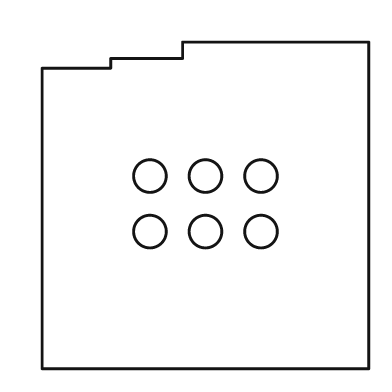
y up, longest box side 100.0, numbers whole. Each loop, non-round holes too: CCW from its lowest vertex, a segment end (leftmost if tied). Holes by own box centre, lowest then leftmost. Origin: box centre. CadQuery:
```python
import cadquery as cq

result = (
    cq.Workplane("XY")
    .moveTo(-50.0, -50.0)
    .lineTo(50.0, -50.0)
    .lineTo(50.0, 50.0)
    .lineTo(-7.0, 50.0)
    .lineTo(-7.0, 45.0)
    .lineTo(-29.0, 45.0)
    .lineTo(-29.0, 42.0)
    .lineTo(-50.0, 42.0)
    .close()
    .moveTo(-17.0, -8.0)
    .circle(5.0)
    .moveTo(0.0, -8.0)
    .circle(5.0)
    .moveTo(17.0, -8.0)
    .circle(5.0)
    .moveTo(-17.0, 9.0)
    .circle(5.0)
    .moveTo(0.0, 9.0)
    .circle(5.0)
    .moveTo(17.0, 9.0)
    .circle(5.0)
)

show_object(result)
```